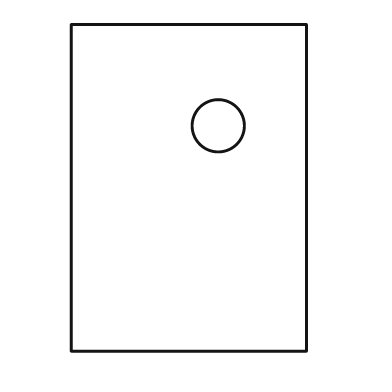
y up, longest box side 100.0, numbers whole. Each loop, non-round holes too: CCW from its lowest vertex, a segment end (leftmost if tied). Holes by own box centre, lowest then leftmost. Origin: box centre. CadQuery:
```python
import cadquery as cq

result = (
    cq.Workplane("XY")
    .moveTo(-36.0, -50.0)
    .lineTo(36.0, -50.0)
    .lineTo(36.0, 50.0)
    .lineTo(-36.0, 50.0)
    .close()
    .moveTo(9.0, 19.0)
    .circle(8.0)
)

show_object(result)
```